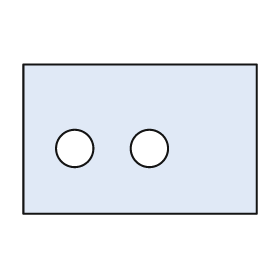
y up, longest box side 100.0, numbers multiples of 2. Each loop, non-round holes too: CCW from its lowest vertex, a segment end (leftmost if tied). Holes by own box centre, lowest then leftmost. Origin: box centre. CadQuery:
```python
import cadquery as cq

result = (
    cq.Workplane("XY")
    .moveTo(-50.0, -32.0)
    .lineTo(50.0, -32.0)
    .lineTo(50.0, 32.0)
    .lineTo(-50.0, 32.0)
    .close()
    .moveTo(-28.0, -4.0)
    .circle(8.0)
    .moveTo(4.0, -4.0)
    .circle(8.0)
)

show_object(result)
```